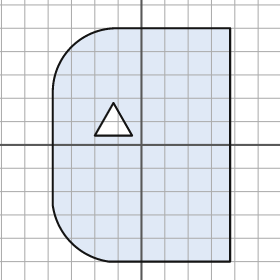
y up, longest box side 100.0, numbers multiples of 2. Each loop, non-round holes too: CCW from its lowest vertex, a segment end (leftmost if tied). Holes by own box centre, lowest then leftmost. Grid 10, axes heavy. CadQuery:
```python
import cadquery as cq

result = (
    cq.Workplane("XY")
    .moveTo(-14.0, -50.0)
    .lineTo(38.0, -50.0)
    .lineTo(38.0, 50.0)
    .lineTo(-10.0, 50.0)
    .threePointArc((-30.0, 42.0), (-38.0, 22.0))
    .lineTo(-38.0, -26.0)
    .threePointArc((-30.0, -42.0), (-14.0, -50.0))
    .close()
    .moveTo(-20.0, 4.0)
    .lineTo(-4.0, 4.0)
    .lineTo(-12.0, 18.0)
    .close()
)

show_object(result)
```